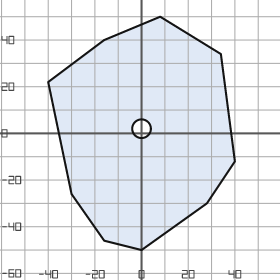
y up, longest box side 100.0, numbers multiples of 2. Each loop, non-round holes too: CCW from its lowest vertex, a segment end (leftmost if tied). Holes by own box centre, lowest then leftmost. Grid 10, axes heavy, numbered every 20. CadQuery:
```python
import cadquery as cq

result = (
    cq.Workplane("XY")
    .moveTo(0.0, -50.0)
    .lineTo(28.0, -30.0)
    .lineTo(40.0, -12.0)
    .lineTo(34.0, 34.0)
    .lineTo(8.0, 50.0)
    .lineTo(-16.0, 40.0)
    .lineTo(-40.0, 22.0)
    .lineTo(-30.0, -26.0)
    .lineTo(-16.0, -46.0)
    .close()
    .moveTo(0.0, 2.0)
    .circle(4.0)
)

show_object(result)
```